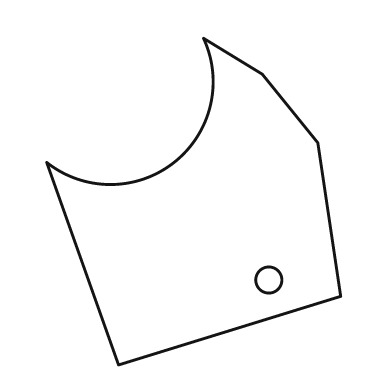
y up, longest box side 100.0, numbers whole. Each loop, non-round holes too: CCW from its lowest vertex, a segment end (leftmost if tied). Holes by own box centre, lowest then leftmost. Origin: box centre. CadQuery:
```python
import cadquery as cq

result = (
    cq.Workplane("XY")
    .moveTo(-23.0, -50.0)
    .lineTo(45.0, -29.0)
    .lineTo(38.0, 18.0)
    .lineTo(21.0, 39.0)
    .lineTo(3.0, 50.0)
    .threePointArc((-6.0, 12.0), (-45.0, 12.0))
    .close()
    .moveTo(23.0, -24.0)
    .circle(4.0)
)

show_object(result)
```